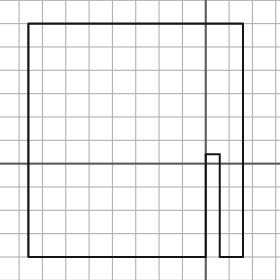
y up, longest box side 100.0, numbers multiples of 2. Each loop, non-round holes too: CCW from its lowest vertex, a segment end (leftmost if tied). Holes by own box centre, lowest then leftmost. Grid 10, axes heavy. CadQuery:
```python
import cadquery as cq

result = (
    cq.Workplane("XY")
    .moveTo(-76.0, -40.0)
    .lineTo(0.0, -40.0)
    .lineTo(0.0, 4.0)
    .lineTo(6.0, 4.0)
    .lineTo(6.0, -40.0)
    .lineTo(16.0, -40.0)
    .lineTo(16.0, 60.0)
    .lineTo(-76.0, 60.0)
    .close()
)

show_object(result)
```